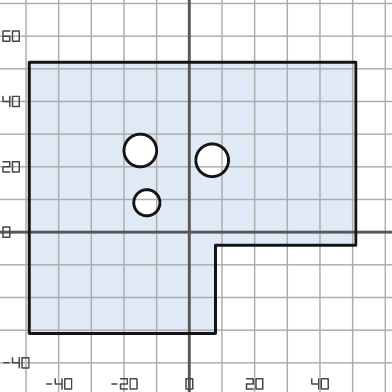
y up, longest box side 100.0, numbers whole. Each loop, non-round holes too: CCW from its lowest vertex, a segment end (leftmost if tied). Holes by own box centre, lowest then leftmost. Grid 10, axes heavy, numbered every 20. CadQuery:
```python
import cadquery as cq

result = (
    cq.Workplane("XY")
    .moveTo(-49.0, -31.0)
    .lineTo(8.0, -31.0)
    .lineTo(8.0, -4.0)
    .lineTo(51.0, -4.0)
    .lineTo(51.0, 52.0)
    .lineTo(-49.0, 52.0)
    .close()
    .moveTo(-13.0, 9.0)
    .circle(4.0)
    .moveTo(7.0, 22.0)
    .circle(5.0)
    .moveTo(-15.0, 25.0)
    .circle(5.0)
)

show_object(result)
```